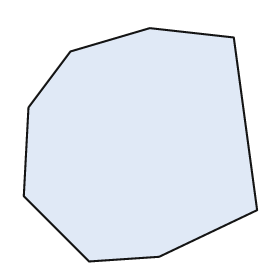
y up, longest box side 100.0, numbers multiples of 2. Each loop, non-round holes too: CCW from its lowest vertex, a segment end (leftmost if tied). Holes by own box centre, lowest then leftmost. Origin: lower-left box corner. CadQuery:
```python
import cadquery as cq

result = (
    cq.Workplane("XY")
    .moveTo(28.0, 0.0)
    .lineTo(58.0, 2.0)
    .lineTo(100.0, 22.0)
    .lineTo(90.0, 96.0)
    .lineTo(54.0, 100.0)
    .lineTo(20.0, 90.0)
    .lineTo(2.0, 66.0)
    .lineTo(0.0, 28.0)
    .close()
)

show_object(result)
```